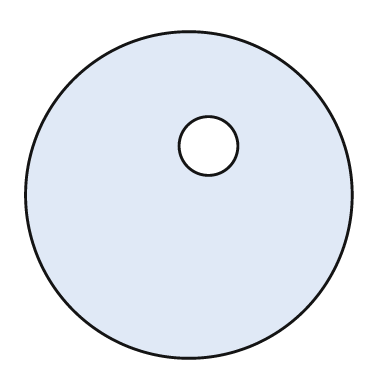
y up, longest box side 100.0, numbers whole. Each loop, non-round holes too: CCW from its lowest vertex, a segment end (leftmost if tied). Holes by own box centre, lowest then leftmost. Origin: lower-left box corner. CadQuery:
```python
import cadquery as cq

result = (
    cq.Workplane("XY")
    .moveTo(50.0, 50.0)
    .circle(50.0)
    .moveTo(56.0, 65.0)
    .circle(9.0)
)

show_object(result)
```